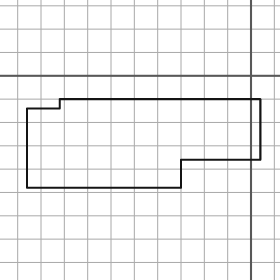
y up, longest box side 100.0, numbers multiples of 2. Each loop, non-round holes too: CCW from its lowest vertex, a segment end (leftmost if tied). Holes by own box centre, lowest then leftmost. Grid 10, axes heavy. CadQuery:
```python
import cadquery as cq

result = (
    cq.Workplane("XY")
    .moveTo(-96.0, -48.0)
    .lineTo(-30.0, -48.0)
    .lineTo(-30.0, -36.0)
    .lineTo(4.0, -36.0)
    .lineTo(4.0, -10.0)
    .lineTo(-82.0, -10.0)
    .lineTo(-82.0, -14.0)
    .lineTo(-96.0, -14.0)
    .close()
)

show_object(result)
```